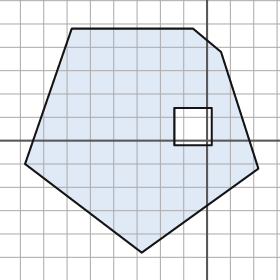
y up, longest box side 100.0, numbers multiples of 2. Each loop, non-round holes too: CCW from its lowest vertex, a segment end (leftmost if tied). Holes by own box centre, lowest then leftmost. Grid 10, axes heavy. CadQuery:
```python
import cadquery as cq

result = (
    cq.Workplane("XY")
    .moveTo(-28.0, -48.0)
    .lineTo(22.0, -12.0)
    .lineTo(6.0, 38.0)
    .lineTo(-6.0, 48.0)
    .lineTo(-58.0, 48.0)
    .lineTo(-78.0, -10.0)
    .close()
    .moveTo(-14.0, -2.0)
    .lineTo(2.0, -2.0)
    .lineTo(2.0, 14.0)
    .lineTo(-14.0, 14.0)
    .close()
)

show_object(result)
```